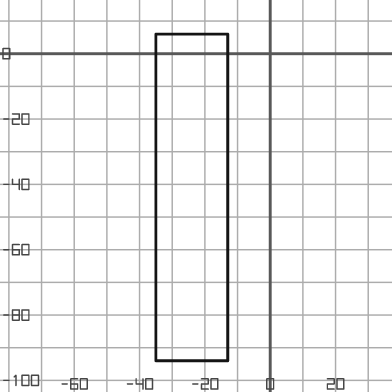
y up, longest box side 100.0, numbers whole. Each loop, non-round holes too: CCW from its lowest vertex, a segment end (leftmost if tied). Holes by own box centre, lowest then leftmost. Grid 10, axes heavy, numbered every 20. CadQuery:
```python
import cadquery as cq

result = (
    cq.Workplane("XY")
    .moveTo(-35.0, -94.0)
    .lineTo(-13.0, -94.0)
    .lineTo(-13.0, 6.0)
    .lineTo(-35.0, 6.0)
    .close()
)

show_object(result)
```